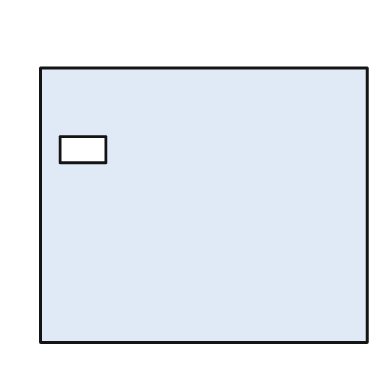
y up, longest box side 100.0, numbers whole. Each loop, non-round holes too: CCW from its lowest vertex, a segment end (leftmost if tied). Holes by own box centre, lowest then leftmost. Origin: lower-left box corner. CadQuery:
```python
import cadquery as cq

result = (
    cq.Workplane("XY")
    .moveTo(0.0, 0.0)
    .lineTo(100.0, 0.0)
    .lineTo(100.0, 84.0)
    .lineTo(0.0, 84.0)
    .close()
    .moveTo(6.0, 55.0)
    .lineTo(20.0, 55.0)
    .lineTo(20.0, 63.0)
    .lineTo(6.0, 63.0)
    .close()
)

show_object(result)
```